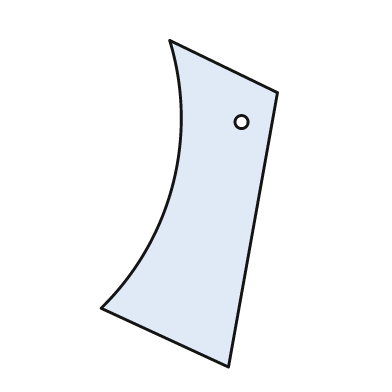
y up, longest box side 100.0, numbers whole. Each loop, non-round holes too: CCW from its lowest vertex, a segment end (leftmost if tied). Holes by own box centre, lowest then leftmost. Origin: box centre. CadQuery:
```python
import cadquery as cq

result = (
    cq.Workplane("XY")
    .moveTo(12.0, -50.0)
    .lineTo(27.0, 34.0)
    .lineTo(-6.0, 50.0)
    .threePointArc((-5.0, 6.0), (-27.0, -32.0))
    .close()
    .moveTo(16.0, 25.0)
    .circle(2.0)
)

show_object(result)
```